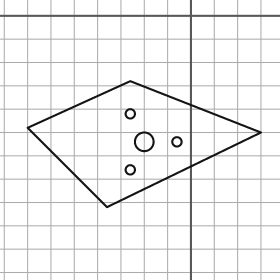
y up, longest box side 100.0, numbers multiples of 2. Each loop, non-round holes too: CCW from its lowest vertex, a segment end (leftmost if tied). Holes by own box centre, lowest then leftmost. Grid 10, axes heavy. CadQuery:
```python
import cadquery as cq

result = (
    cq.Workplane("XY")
    .moveTo(-36.0, -82.0)
    .lineTo(30.0, -50.0)
    .lineTo(-26.0, -28.0)
    .lineTo(-70.0, -48.0)
    .close()
    .moveTo(-26.0, -66.0)
    .circle(2.0)
    .moveTo(-20.0, -54.0)
    .circle(4.0)
    .moveTo(-6.0, -54.0)
    .circle(2.0)
    .moveTo(-26.0, -42.0)
    .circle(2.0)
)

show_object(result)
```